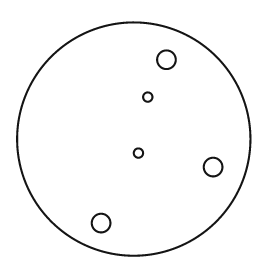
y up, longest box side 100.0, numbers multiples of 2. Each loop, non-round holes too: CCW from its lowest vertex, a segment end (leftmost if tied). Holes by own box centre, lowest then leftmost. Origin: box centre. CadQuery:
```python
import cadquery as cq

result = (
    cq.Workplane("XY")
    .moveTo(0.0, 0.0)
    .circle(50.0)
    .moveTo(-14.0, -36.0)
    .circle(4.0)
    .moveTo(34.0, -12.0)
    .circle(4.0)
    .moveTo(2.0, -6.0)
    .circle(2.0)
    .moveTo(6.0, 18.0)
    .circle(2.0)
    .moveTo(14.0, 34.0)
    .circle(4.0)
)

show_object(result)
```